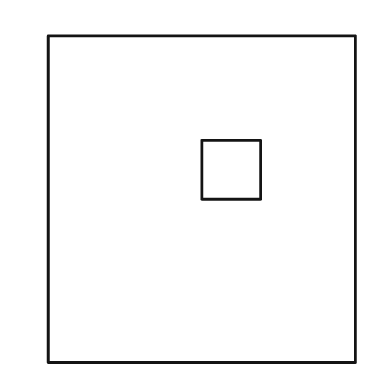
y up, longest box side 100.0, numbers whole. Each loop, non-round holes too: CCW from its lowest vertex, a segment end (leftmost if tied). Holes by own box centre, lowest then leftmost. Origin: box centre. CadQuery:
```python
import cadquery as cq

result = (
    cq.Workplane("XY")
    .moveTo(-47.0, -50.0)
    .lineTo(47.0, -50.0)
    .lineTo(47.0, 50.0)
    .lineTo(-47.0, 50.0)
    .close()
    .moveTo(0.0, 0.0)
    .lineTo(18.0, 0.0)
    .lineTo(18.0, 18.0)
    .lineTo(0.0, 18.0)
    .close()
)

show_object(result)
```